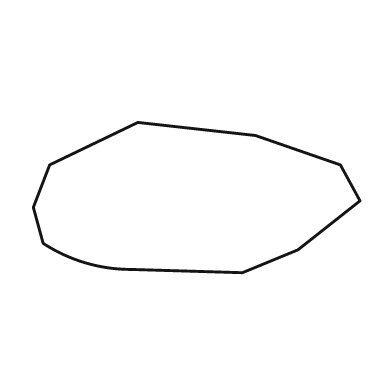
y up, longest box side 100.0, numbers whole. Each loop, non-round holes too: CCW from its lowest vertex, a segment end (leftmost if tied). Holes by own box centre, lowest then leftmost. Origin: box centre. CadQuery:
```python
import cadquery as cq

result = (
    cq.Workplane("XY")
    .moveTo(14.0, -23.0)
    .lineTo(31.0, -16.0)
    .lineTo(50.0, -1.0)
    .lineTo(44.0, 10.0)
    .lineTo(18.0, 19.0)
    .lineTo(-18.0, 23.0)
    .lineTo(-45.0, 10.0)
    .lineTo(-50.0, -3.0)
    .lineTo(-47.0, -14.0)
    .threePointArc((-34.0, -20.0), (-20.0, -22.0))
    .close()
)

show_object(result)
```